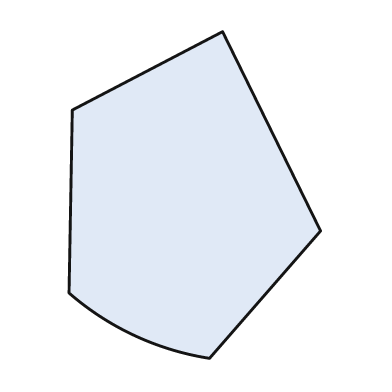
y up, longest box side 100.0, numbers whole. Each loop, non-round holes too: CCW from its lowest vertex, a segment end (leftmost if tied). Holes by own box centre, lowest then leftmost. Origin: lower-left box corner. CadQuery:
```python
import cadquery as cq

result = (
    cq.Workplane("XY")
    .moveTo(43.0, 0.0)
    .lineTo(77.0, 39.0)
    .lineTo(47.0, 100.0)
    .lineTo(1.0, 76.0)
    .lineTo(0.0, 20.0)
    .threePointArc((20.0, 7.0), (43.0, 0.0))
    .close()
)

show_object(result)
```